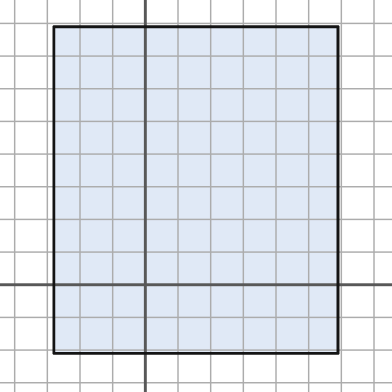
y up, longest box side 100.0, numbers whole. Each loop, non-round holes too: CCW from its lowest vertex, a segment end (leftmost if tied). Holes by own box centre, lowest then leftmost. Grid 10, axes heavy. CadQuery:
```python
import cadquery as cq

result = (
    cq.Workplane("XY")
    .moveTo(-28.0, -21.0)
    .lineTo(59.0, -21.0)
    .lineTo(59.0, 79.0)
    .lineTo(-28.0, 79.0)
    .close()
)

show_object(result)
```